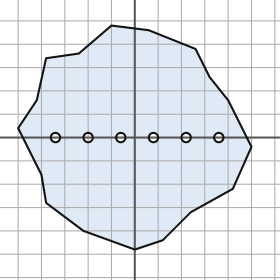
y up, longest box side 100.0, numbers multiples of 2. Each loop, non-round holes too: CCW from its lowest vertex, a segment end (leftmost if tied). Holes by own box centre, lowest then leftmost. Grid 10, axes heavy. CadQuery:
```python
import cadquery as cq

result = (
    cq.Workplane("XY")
    .moveTo(0.0, -48.0)
    .lineTo(12.0, -44.0)
    .lineTo(24.0, -32.0)
    .lineTo(42.0, -22.0)
    .lineTo(50.0, -4.0)
    .lineTo(40.0, 16.0)
    .lineTo(32.0, 26.0)
    .lineTo(26.0, 38.0)
    .lineTo(6.0, 46.0)
    .lineTo(-10.0, 48.0)
    .lineTo(-24.0, 36.0)
    .lineTo(-38.0, 34.0)
    .lineTo(-42.0, 16.0)
    .lineTo(-50.0, 4.0)
    .lineTo(-40.0, -16.0)
    .lineTo(-38.0, -28.0)
    .lineTo(-22.0, -40.0)
    .close()
    .moveTo(-34.0, 0.0)
    .circle(2.0)
    .moveTo(-20.0, 0.0)
    .circle(2.0)
    .moveTo(-6.0, 0.0)
    .circle(2.0)
    .moveTo(8.0, 0.0)
    .circle(2.0)
    .moveTo(22.0, 0.0)
    .circle(2.0)
    .moveTo(36.0, 0.0)
    .circle(2.0)
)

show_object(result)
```